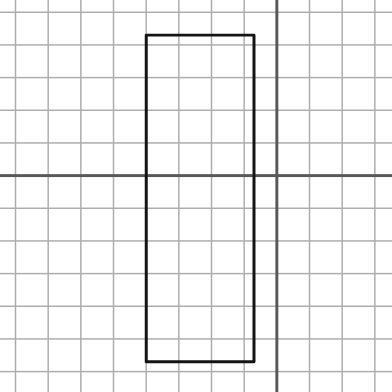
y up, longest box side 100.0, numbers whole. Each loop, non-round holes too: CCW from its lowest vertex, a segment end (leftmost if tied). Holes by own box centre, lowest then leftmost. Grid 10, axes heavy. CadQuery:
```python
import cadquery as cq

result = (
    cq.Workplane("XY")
    .moveTo(-40.0, -57.0)
    .lineTo(-7.0, -57.0)
    .lineTo(-7.0, 43.0)
    .lineTo(-40.0, 43.0)
    .close()
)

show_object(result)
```